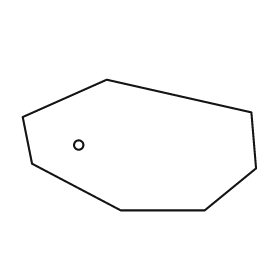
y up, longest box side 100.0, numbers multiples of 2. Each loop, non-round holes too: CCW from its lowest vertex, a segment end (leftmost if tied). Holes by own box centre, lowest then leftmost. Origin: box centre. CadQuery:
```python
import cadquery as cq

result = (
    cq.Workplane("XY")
    .moveTo(-8.0, -28.0)
    .lineTo(28.0, -28.0)
    .lineTo(50.0, -10.0)
    .lineTo(48.0, 14.0)
    .lineTo(-14.0, 28.0)
    .lineTo(-50.0, 12.0)
    .lineTo(-46.0, -8.0)
    .close()
    .moveTo(-26.0, 0.0)
    .circle(2.0)
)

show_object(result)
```